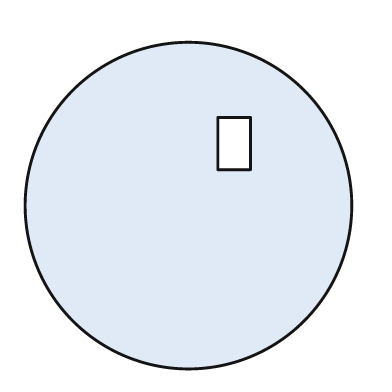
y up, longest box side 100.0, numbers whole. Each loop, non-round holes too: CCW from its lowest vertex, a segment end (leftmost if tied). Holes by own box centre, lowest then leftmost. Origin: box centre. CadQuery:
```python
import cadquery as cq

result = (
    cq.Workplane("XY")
    .moveTo(0.0, 0.0)
    .circle(50.0)
    .moveTo(9.0, 11.0)
    .lineTo(19.0, 11.0)
    .lineTo(19.0, 27.0)
    .lineTo(9.0, 27.0)
    .close()
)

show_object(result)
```